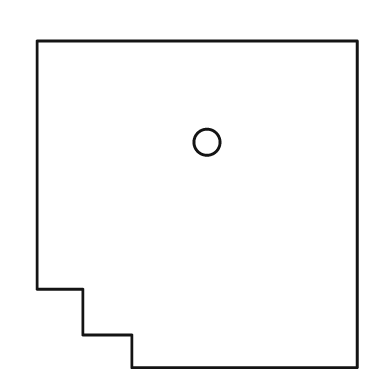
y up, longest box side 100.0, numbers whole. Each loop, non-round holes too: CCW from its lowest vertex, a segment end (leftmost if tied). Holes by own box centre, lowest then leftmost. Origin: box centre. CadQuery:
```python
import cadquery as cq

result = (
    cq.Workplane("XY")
    .moveTo(-20.0, -50.0)
    .lineTo(49.0, -50.0)
    .lineTo(49.0, 50.0)
    .lineTo(-49.0, 50.0)
    .lineTo(-49.0, -26.0)
    .lineTo(-35.0, -26.0)
    .lineTo(-35.0, -40.0)
    .lineTo(-20.0, -40.0)
    .close()
    .moveTo(3.0, 19.0)
    .circle(4.0)
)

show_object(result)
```